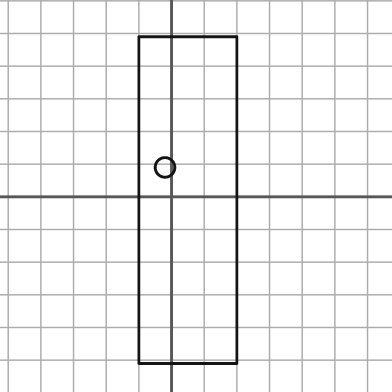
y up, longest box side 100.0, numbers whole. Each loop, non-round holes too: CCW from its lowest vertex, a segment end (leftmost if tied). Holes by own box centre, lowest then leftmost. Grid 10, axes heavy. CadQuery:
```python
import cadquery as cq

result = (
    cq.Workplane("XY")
    .moveTo(-10.0, -51.0)
    .lineTo(20.0, -51.0)
    .lineTo(20.0, 49.0)
    .lineTo(-10.0, 49.0)
    .close()
    .moveTo(-2.0, 9.0)
    .circle(3.0)
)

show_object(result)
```